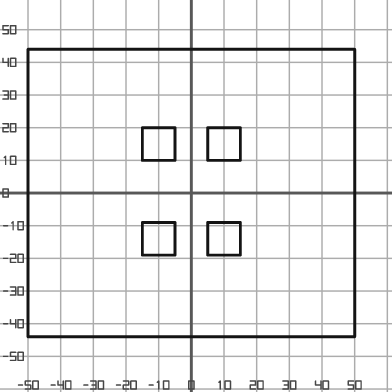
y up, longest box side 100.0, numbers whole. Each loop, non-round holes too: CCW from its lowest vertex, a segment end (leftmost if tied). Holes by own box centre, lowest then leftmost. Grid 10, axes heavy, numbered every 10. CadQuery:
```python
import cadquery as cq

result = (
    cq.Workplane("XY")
    .moveTo(-50.0, -44.0)
    .lineTo(50.0, -44.0)
    .lineTo(50.0, 44.0)
    .lineTo(-50.0, 44.0)
    .close()
    .moveTo(-15.0, -19.0)
    .lineTo(-5.0, -19.0)
    .lineTo(-5.0, -9.0)
    .lineTo(-15.0, -9.0)
    .close()
    .moveTo(5.0, -19.0)
    .lineTo(15.0, -19.0)
    .lineTo(15.0, -9.0)
    .lineTo(5.0, -9.0)
    .close()
    .moveTo(-15.0, 10.0)
    .lineTo(-5.0, 10.0)
    .lineTo(-5.0, 20.0)
    .lineTo(-15.0, 20.0)
    .close()
    .moveTo(5.0, 10.0)
    .lineTo(15.0, 10.0)
    .lineTo(15.0, 20.0)
    .lineTo(5.0, 20.0)
    .close()
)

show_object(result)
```